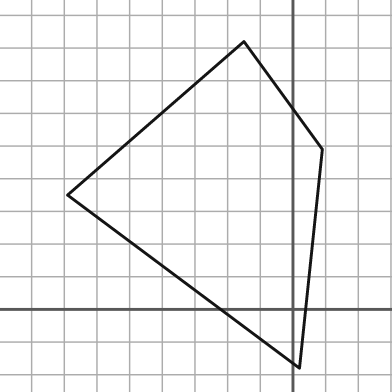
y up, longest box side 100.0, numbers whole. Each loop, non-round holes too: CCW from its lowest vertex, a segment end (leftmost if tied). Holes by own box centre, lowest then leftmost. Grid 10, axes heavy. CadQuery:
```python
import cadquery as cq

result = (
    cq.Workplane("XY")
    .moveTo(2.0, -18.0)
    .lineTo(9.0, 49.0)
    .lineTo(-15.0, 82.0)
    .lineTo(-69.0, 35.0)
    .close()
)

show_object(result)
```